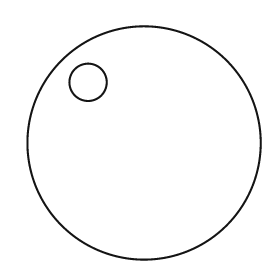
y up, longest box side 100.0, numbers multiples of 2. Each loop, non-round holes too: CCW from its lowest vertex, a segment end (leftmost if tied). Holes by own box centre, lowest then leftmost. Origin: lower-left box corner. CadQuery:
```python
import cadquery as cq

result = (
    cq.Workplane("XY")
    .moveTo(50.0, 50.0)
    .circle(50.0)
    .moveTo(26.0, 76.0)
    .circle(8.0)
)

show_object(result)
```